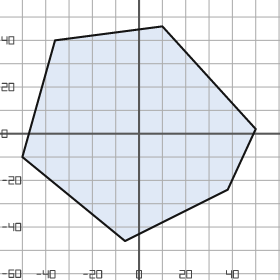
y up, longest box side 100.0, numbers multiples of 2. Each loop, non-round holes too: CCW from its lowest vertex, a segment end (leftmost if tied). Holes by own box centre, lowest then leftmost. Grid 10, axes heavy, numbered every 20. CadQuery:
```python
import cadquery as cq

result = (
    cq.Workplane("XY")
    .moveTo(-6.0, -46.0)
    .lineTo(38.0, -24.0)
    .lineTo(50.0, 2.0)
    .lineTo(10.0, 46.0)
    .lineTo(-36.0, 40.0)
    .lineTo(-50.0, -10.0)
    .close()
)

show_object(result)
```